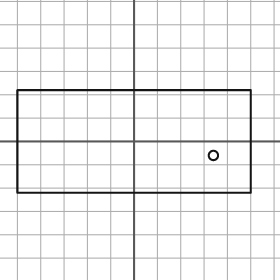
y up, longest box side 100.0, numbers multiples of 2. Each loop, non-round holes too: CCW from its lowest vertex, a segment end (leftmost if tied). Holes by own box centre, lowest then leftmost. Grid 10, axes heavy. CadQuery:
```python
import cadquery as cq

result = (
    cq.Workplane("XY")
    .moveTo(-50.0, -22.0)
    .lineTo(50.0, -22.0)
    .lineTo(50.0, 22.0)
    .lineTo(-50.0, 22.0)
    .close()
    .moveTo(34.0, -6.0)
    .circle(2.0)
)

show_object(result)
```